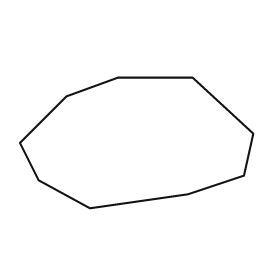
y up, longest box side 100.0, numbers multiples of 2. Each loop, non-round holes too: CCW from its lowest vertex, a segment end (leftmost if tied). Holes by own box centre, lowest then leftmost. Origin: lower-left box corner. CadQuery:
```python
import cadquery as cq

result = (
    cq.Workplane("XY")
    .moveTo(30.0, 0.0)
    .lineTo(72.0, 6.0)
    .lineTo(96.0, 14.0)
    .lineTo(100.0, 32.0)
    .lineTo(74.0, 56.0)
    .lineTo(42.0, 56.0)
    .lineTo(20.0, 48.0)
    .lineTo(0.0, 28.0)
    .lineTo(8.0, 12.0)
    .close()
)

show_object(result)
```